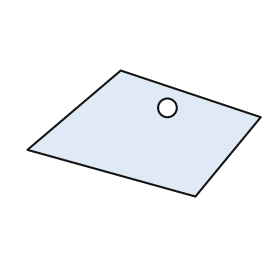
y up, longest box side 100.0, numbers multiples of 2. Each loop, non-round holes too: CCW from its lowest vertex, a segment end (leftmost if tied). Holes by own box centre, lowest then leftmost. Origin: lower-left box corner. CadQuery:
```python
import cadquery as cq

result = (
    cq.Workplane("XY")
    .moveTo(72.0, 0.0)
    .lineTo(100.0, 34.0)
    .lineTo(40.0, 54.0)
    .lineTo(0.0, 20.0)
    .close()
    .moveTo(60.0, 38.0)
    .circle(4.0)
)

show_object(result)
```